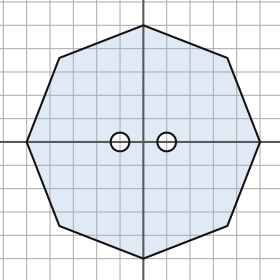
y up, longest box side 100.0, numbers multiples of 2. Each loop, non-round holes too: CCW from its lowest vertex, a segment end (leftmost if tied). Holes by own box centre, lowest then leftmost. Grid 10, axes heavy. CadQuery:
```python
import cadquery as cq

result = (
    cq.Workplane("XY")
    .moveTo(0.0, -50.0)
    .lineTo(36.0, -36.0)
    .lineTo(50.0, 0.0)
    .lineTo(36.0, 36.0)
    .lineTo(0.0, 50.0)
    .lineTo(-36.0, 36.0)
    .lineTo(-50.0, 0.0)
    .lineTo(-36.0, -36.0)
    .close()
    .moveTo(-10.0, 0.0)
    .circle(4.0)
    .moveTo(10.0, 0.0)
    .circle(4.0)
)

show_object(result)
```